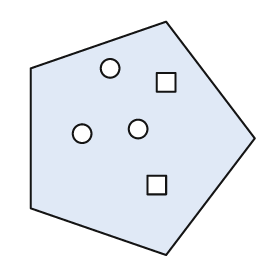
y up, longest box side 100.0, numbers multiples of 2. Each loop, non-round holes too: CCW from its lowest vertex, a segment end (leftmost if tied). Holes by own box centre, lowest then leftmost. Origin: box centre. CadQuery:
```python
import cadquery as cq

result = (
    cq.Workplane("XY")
    .moveTo(10.0, -50.0)
    .lineTo(48.0, 0.0)
    .lineTo(10.0, 50.0)
    .lineTo(-48.0, 30.0)
    .lineTo(-48.0, -30.0)
    .close()
    .moveTo(2.0, -24.0)
    .lineTo(10.0, -24.0)
    .lineTo(10.0, -16.0)
    .lineTo(2.0, -16.0)
    .close()
    .moveTo(-26.0, 2.0)
    .circle(4.0)
    .moveTo(-2.0, 4.0)
    .circle(4.0)
    .moveTo(6.0, 20.0)
    .lineTo(14.0, 20.0)
    .lineTo(14.0, 28.0)
    .lineTo(6.0, 28.0)
    .close()
    .moveTo(-14.0, 30.0)
    .circle(4.0)
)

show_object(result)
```